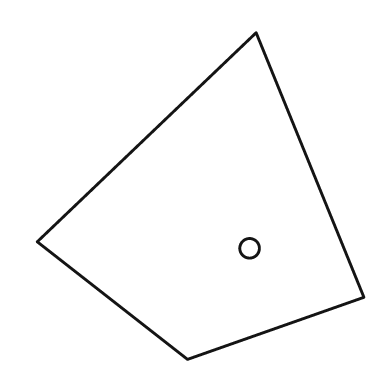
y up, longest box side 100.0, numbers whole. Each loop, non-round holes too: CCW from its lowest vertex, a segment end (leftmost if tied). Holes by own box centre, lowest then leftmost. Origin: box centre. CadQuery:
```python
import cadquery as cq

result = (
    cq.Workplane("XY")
    .moveTo(-4.0, -50.0)
    .lineTo(50.0, -31.0)
    .lineTo(17.0, 50.0)
    .lineTo(-50.0, -14.0)
    .close()
    .moveTo(15.0, -16.0)
    .circle(3.0)
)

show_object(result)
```